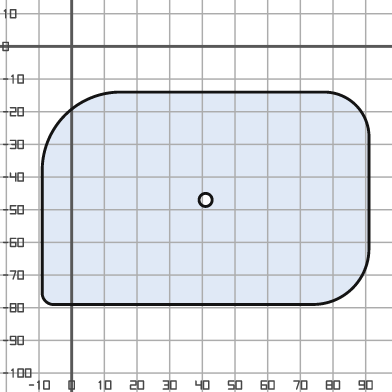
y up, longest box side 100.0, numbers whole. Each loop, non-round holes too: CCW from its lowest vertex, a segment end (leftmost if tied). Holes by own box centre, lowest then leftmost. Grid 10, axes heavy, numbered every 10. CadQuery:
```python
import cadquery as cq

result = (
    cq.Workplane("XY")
    .moveTo(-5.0, -79.0)
    .lineTo(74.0, -79.0)
    .threePointArc((86.0, -74.0), (91.0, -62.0))
    .lineTo(91.0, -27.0)
    .threePointArc((87.0, -18.0), (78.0, -14.0))
    .lineTo(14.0, -14.0)
    .threePointArc((-2.0, -21.0), (-9.0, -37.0))
    .lineTo(-9.0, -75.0)
    .threePointArc((-8.0, -78.0), (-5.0, -79.0))
    .close()
    .moveTo(41.0, -47.0)
    .circle(2.0)
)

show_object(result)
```